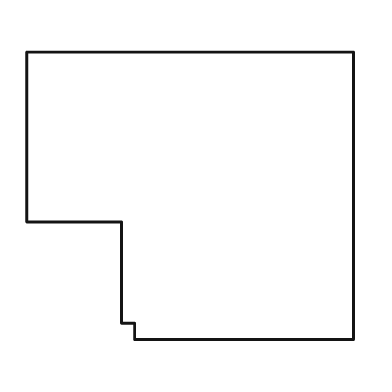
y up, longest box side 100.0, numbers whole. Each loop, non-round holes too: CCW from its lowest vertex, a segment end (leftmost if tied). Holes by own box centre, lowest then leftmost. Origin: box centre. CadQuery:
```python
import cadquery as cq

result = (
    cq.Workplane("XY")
    .moveTo(-17.0, -44.0)
    .lineTo(50.0, -44.0)
    .lineTo(50.0, 44.0)
    .lineTo(-50.0, 44.0)
    .lineTo(-50.0, -8.0)
    .lineTo(-21.0, -8.0)
    .lineTo(-21.0, -39.0)
    .lineTo(-17.0, -39.0)
    .close()
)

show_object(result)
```